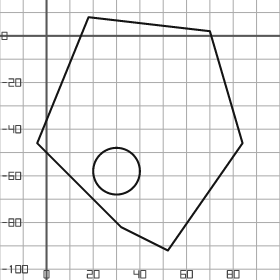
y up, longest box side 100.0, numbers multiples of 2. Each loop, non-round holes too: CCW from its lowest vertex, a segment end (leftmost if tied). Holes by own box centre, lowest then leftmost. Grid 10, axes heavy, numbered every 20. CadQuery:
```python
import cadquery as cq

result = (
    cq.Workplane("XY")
    .moveTo(52.0, -92.0)
    .lineTo(84.0, -46.0)
    .lineTo(70.0, 2.0)
    .lineTo(18.0, 8.0)
    .lineTo(-4.0, -46.0)
    .lineTo(32.0, -82.0)
    .close()
    .moveTo(30.0, -58.0)
    .circle(10.0)
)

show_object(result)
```